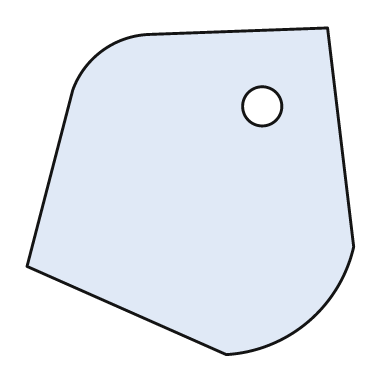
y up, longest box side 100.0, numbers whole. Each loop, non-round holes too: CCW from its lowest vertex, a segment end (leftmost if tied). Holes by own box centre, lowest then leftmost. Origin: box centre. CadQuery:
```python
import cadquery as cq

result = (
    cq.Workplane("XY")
    .moveTo(11.0, -50.0)
    .threePointArc((36.0, -40.0), (50.0, -17.0))
    .lineTo(42.0, 50.0)
    .lineTo(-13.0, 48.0)
    .threePointArc((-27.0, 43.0), (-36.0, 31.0))
    .lineTo(-50.0, -23.0)
    .close()
    .moveTo(22.0, 26.0)
    .circle(6.0)
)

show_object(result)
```